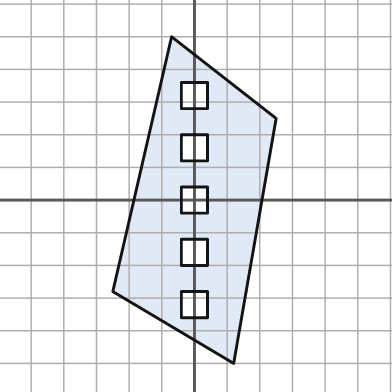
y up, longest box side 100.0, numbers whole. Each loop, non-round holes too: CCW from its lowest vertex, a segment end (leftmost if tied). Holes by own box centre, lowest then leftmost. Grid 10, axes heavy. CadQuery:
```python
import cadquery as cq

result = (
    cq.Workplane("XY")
    .moveTo(12.0, -50.0)
    .lineTo(25.0, 25.0)
    .lineTo(-7.0, 50.0)
    .lineTo(-25.0, -28.0)
    .close()
    .moveTo(-4.0, -36.0)
    .lineTo(4.0, -36.0)
    .lineTo(4.0, -28.0)
    .lineTo(-4.0, -28.0)
    .close()
    .moveTo(-4.0, -20.0)
    .lineTo(4.0, -20.0)
    .lineTo(4.0, -12.0)
    .lineTo(-4.0, -12.0)
    .close()
    .moveTo(-4.0, -4.0)
    .lineTo(4.0, -4.0)
    .lineTo(4.0, 4.0)
    .lineTo(-4.0, 4.0)
    .close()
    .moveTo(-4.0, 12.0)
    .lineTo(4.0, 12.0)
    .lineTo(4.0, 20.0)
    .lineTo(-4.0, 20.0)
    .close()
    .moveTo(-4.0, 28.0)
    .lineTo(4.0, 28.0)
    .lineTo(4.0, 36.0)
    .lineTo(-4.0, 36.0)
    .close()
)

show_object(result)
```